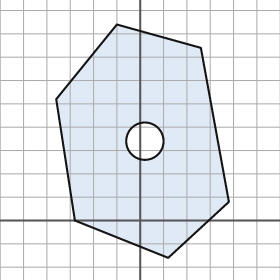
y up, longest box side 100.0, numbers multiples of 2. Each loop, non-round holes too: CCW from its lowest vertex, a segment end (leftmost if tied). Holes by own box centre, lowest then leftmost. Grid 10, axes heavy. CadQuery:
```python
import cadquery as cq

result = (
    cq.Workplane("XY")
    .moveTo(12.0, -16.0)
    .lineTo(38.0, 8.0)
    .lineTo(26.0, 74.0)
    .lineTo(-10.0, 84.0)
    .lineTo(-36.0, 52.0)
    .lineTo(-28.0, 0.0)
    .close()
    .moveTo(2.0, 34.0)
    .circle(8.0)
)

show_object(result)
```